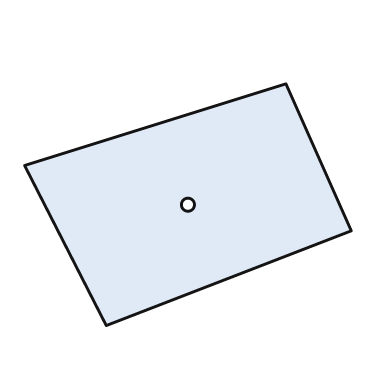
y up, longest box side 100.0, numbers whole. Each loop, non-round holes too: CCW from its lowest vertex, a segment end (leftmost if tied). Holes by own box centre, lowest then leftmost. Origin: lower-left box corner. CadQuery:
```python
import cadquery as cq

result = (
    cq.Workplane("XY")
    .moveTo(25.0, 0.0)
    .lineTo(100.0, 29.0)
    .lineTo(80.0, 74.0)
    .lineTo(0.0, 49.0)
    .close()
    .moveTo(50.0, 37.0)
    .circle(2.0)
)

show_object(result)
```